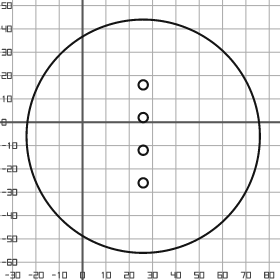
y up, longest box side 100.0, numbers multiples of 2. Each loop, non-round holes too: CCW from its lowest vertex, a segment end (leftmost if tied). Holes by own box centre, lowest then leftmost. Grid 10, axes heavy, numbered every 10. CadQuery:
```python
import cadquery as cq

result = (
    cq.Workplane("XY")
    .moveTo(26.0, -6.0)
    .circle(50.0)
    .moveTo(26.0, -26.0)
    .circle(2.0)
    .moveTo(26.0, -12.0)
    .circle(2.0)
    .moveTo(26.0, 2.0)
    .circle(2.0)
    .moveTo(26.0, 16.0)
    .circle(2.0)
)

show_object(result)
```